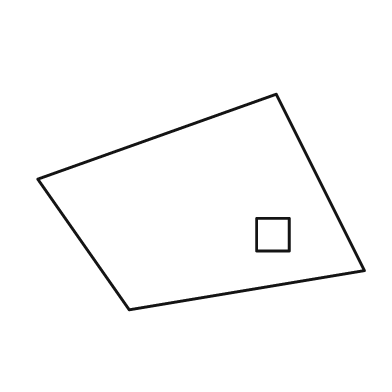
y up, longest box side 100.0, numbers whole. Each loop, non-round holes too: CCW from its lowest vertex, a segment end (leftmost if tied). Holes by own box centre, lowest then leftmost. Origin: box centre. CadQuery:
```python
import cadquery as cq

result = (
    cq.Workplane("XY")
    .moveTo(-22.0, -33.0)
    .lineTo(50.0, -21.0)
    .lineTo(23.0, 33.0)
    .lineTo(-50.0, 7.0)
    .close()
    .moveTo(17.0, -15.0)
    .lineTo(27.0, -15.0)
    .lineTo(27.0, -5.0)
    .lineTo(17.0, -5.0)
    .close()
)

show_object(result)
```